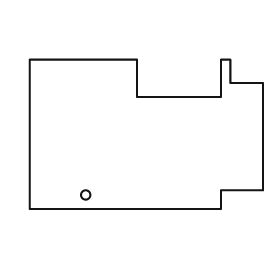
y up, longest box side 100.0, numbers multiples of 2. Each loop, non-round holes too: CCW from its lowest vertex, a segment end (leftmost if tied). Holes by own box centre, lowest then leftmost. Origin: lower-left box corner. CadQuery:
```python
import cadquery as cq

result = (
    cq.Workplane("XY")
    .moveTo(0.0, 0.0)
    .lineTo(82.0, 0.0)
    .lineTo(82.0, 8.0)
    .lineTo(100.0, 8.0)
    .lineTo(100.0, 54.0)
    .lineTo(86.0, 54.0)
    .lineTo(86.0, 64.0)
    .lineTo(82.0, 64.0)
    .lineTo(82.0, 48.0)
    .lineTo(46.0, 48.0)
    .lineTo(46.0, 64.0)
    .lineTo(0.0, 64.0)
    .close()
    .moveTo(24.0, 6.0)
    .circle(2.0)
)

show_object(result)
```